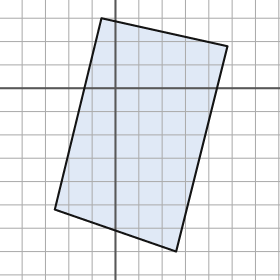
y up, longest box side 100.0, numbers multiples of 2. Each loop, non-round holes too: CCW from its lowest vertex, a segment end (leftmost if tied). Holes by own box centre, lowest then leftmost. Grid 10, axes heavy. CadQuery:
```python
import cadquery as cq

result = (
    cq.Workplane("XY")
    .moveTo(26.0, -70.0)
    .lineTo(48.0, 18.0)
    .lineTo(-6.0, 30.0)
    .lineTo(-26.0, -52.0)
    .close()
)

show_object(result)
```